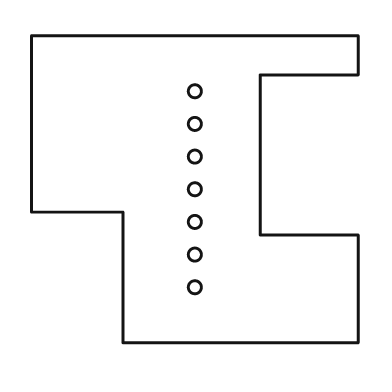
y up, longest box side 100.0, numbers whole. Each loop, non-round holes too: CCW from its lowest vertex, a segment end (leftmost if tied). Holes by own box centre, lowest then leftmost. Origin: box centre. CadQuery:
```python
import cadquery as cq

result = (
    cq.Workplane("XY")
    .moveTo(-22.0, -47.0)
    .lineTo(50.0, -47.0)
    .lineTo(50.0, -14.0)
    .lineTo(20.0, -14.0)
    .lineTo(20.0, 35.0)
    .lineTo(50.0, 35.0)
    .lineTo(50.0, 47.0)
    .lineTo(-50.0, 47.0)
    .lineTo(-50.0, -7.0)
    .lineTo(-22.0, -7.0)
    .close()
    .moveTo(0.0, -30.0)
    .circle(2.0)
    .moveTo(0.0, -20.0)
    .circle(2.0)
    .moveTo(0.0, -10.0)
    .circle(2.0)
    .moveTo(0.0, 0.0)
    .circle(2.0)
    .moveTo(0.0, 10.0)
    .circle(2.0)
    .moveTo(0.0, 20.0)
    .circle(2.0)
    .moveTo(0.0, 30.0)
    .circle(2.0)
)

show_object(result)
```